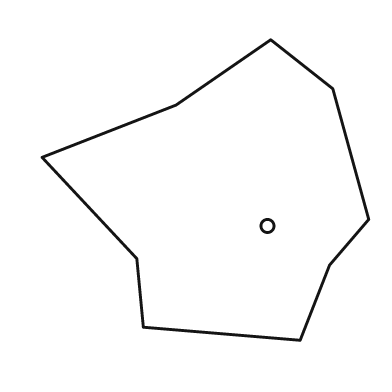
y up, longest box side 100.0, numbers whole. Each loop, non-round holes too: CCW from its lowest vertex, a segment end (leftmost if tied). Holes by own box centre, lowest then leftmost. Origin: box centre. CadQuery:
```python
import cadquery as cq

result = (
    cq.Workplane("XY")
    .moveTo(29.0, -46.0)
    .lineTo(38.0, -23.0)
    .lineTo(50.0, -9.0)
    .lineTo(39.0, 31.0)
    .lineTo(20.0, 46.0)
    .lineTo(-9.0, 26.0)
    .lineTo(-50.0, 10.0)
    .lineTo(-21.0, -21.0)
    .lineTo(-19.0, -42.0)
    .close()
    .moveTo(19.0, -11.0)
    .circle(2.0)
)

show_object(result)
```